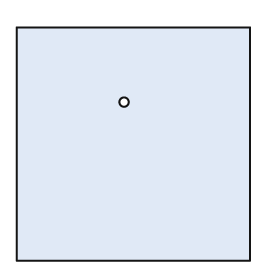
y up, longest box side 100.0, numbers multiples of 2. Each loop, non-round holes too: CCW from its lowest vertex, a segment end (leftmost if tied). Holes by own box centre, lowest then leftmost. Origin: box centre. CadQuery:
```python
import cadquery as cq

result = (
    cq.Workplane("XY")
    .moveTo(-50.0, -50.0)
    .lineTo(50.0, -50.0)
    .lineTo(50.0, 50.0)
    .lineTo(-50.0, 50.0)
    .close()
    .moveTo(-4.0, 18.0)
    .circle(2.0)
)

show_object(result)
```